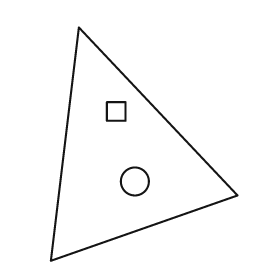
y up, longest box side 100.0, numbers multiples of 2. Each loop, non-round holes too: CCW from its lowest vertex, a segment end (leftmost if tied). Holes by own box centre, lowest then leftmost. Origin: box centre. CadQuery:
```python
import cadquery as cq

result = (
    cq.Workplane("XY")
    .moveTo(-40.0, -50.0)
    .lineTo(40.0, -22.0)
    .lineTo(-28.0, 50.0)
    .close()
    .moveTo(-4.0, -16.0)
    .circle(6.0)
    .moveTo(-16.0, 10.0)
    .lineTo(-8.0, 10.0)
    .lineTo(-8.0, 18.0)
    .lineTo(-16.0, 18.0)
    .close()
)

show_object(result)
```